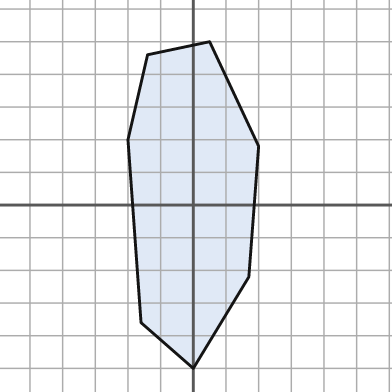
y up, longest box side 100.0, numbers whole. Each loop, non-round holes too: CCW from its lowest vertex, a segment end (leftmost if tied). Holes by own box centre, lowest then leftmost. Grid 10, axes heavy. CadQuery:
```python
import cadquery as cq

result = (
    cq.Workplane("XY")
    .moveTo(0.0, -50.0)
    .lineTo(17.0, -22.0)
    .lineTo(20.0, 18.0)
    .lineTo(5.0, 50.0)
    .lineTo(-14.0, 46.0)
    .lineTo(-20.0, 20.0)
    .lineTo(-16.0, -36.0)
    .close()
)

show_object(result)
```